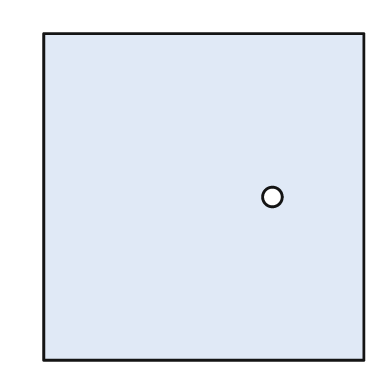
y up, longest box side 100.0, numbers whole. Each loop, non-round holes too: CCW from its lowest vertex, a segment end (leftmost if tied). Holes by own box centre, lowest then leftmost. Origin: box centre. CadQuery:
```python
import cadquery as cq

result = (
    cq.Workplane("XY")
    .moveTo(-49.0, -50.0)
    .lineTo(49.0, -50.0)
    .lineTo(49.0, 50.0)
    .lineTo(-49.0, 50.0)
    .close()
    .moveTo(21.0, 0.0)
    .circle(3.0)
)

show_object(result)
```